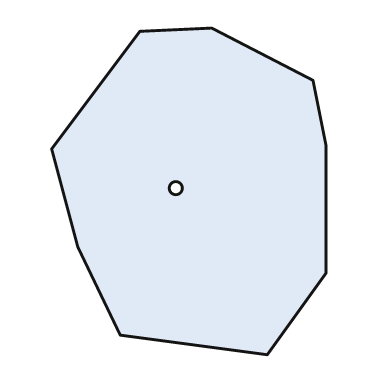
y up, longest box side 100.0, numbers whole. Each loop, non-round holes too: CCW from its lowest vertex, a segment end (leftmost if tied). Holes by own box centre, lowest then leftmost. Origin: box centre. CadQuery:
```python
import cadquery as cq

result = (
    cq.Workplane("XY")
    .moveTo(24.0, -50.0)
    .lineTo(42.0, -25.0)
    .lineTo(42.0, 14.0)
    .lineTo(38.0, 34.0)
    .lineTo(7.0, 50.0)
    .lineTo(-15.0, 49.0)
    .lineTo(-42.0, 13.0)
    .lineTo(-34.0, -17.0)
    .lineTo(-21.0, -44.0)
    .close()
    .moveTo(-4.0, 1.0)
    .circle(2.0)
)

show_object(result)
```